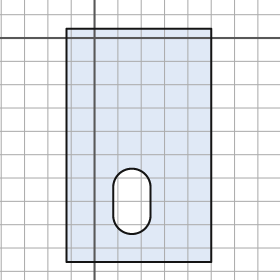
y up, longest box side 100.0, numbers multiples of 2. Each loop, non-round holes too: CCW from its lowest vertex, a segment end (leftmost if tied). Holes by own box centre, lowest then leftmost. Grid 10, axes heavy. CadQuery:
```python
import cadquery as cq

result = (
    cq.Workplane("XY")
    .moveTo(-12.0, -96.0)
    .lineTo(50.0, -96.0)
    .lineTo(50.0, 4.0)
    .lineTo(-12.0, 4.0)
    .close()
    .moveTo(8.0, -76.0)
    .threePointArc((16.0, -84.0), (24.0, -76.0))
    .lineTo(24.0, -64.0)
    .threePointArc((16.0, -56.0), (8.0, -64.0))
    .close()
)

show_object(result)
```